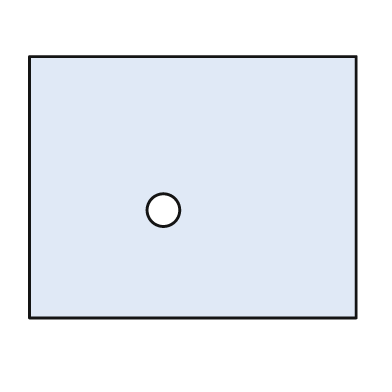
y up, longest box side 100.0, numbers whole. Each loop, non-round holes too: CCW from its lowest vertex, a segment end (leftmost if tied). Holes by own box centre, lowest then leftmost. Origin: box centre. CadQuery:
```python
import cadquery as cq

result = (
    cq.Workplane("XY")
    .moveTo(-50.0, -40.0)
    .lineTo(50.0, -40.0)
    .lineTo(50.0, 40.0)
    .lineTo(-50.0, 40.0)
    .close()
    .moveTo(-9.0, -7.0)
    .circle(5.0)
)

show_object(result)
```